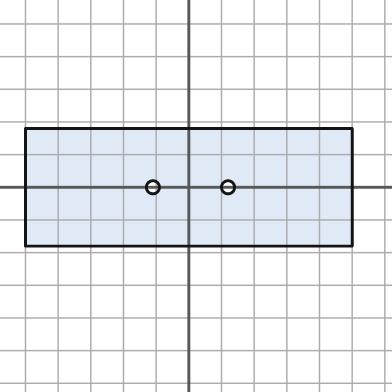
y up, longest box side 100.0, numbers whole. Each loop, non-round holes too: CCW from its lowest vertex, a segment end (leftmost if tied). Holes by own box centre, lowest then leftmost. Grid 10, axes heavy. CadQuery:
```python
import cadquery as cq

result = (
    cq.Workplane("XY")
    .moveTo(-50.0, -18.0)
    .lineTo(50.0, -18.0)
    .lineTo(50.0, 18.0)
    .lineTo(-50.0, 18.0)
    .close()
    .moveTo(-11.0, 0.0)
    .circle(2.0)
    .moveTo(12.0, 0.0)
    .circle(2.0)
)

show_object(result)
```